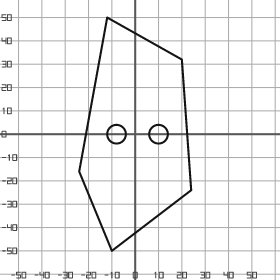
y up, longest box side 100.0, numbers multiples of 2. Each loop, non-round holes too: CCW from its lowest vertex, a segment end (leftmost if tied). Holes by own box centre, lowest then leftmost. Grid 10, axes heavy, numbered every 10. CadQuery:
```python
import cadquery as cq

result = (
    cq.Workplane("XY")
    .moveTo(-10.0, -50.0)
    .lineTo(24.0, -24.0)
    .lineTo(20.0, 32.0)
    .lineTo(-12.0, 50.0)
    .lineTo(-24.0, -16.0)
    .close()
    .moveTo(-8.0, 0.0)
    .circle(4.0)
    .moveTo(10.0, 0.0)
    .circle(4.0)
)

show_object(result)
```